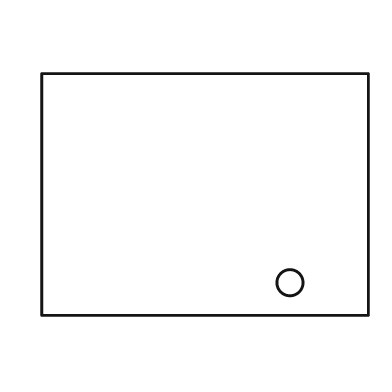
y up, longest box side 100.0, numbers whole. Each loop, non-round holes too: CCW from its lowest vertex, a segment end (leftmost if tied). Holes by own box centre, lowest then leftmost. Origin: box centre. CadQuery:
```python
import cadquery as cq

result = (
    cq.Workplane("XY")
    .moveTo(-50.0, -37.0)
    .lineTo(50.0, -37.0)
    .lineTo(50.0, 37.0)
    .lineTo(-50.0, 37.0)
    .close()
    .moveTo(26.0, -27.0)
    .circle(4.0)
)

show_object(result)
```